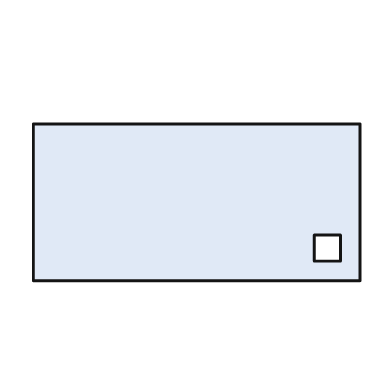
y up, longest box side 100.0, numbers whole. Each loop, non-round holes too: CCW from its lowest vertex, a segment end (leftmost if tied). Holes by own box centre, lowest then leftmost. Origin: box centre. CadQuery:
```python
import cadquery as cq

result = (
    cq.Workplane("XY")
    .moveTo(-50.0, -24.0)
    .lineTo(50.0, -24.0)
    .lineTo(50.0, 24.0)
    .lineTo(-50.0, 24.0)
    .close()
    .moveTo(36.0, -18.0)
    .lineTo(44.0, -18.0)
    .lineTo(44.0, -10.0)
    .lineTo(36.0, -10.0)
    .close()
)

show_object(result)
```